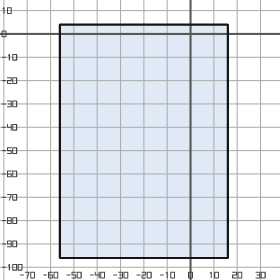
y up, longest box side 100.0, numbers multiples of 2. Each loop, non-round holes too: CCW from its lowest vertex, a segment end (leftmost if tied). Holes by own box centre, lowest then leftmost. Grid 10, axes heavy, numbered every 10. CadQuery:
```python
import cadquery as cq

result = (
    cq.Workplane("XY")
    .moveTo(-56.0, -96.0)
    .lineTo(16.0, -96.0)
    .lineTo(16.0, 4.0)
    .lineTo(-56.0, 4.0)
    .close()
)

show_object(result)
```